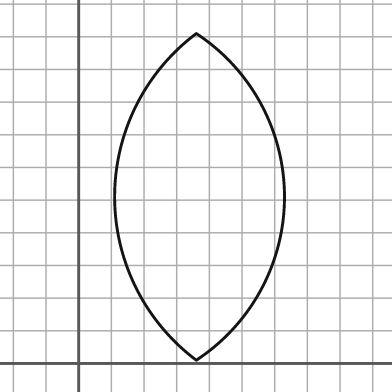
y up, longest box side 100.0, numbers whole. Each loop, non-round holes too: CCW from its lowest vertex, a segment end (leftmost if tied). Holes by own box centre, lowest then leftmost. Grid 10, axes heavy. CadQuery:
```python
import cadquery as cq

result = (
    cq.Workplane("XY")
    .moveTo(36.0, 1.0)
    .threePointArc((63.0, 51.0), (36.0, 101.0))
    .threePointArc((11.0, 51.0), (36.0, 1.0))
    .close()
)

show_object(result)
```